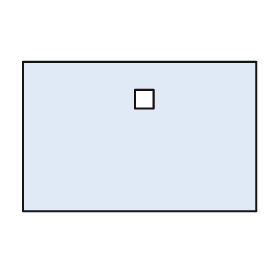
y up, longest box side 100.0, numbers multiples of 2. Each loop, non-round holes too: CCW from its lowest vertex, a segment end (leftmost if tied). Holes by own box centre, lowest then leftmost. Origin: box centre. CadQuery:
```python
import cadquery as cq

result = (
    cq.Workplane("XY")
    .moveTo(-50.0, -32.0)
    .lineTo(50.0, -32.0)
    .lineTo(50.0, 32.0)
    .lineTo(-50.0, 32.0)
    .close()
    .moveTo(-2.0, 12.0)
    .lineTo(6.0, 12.0)
    .lineTo(6.0, 20.0)
    .lineTo(-2.0, 20.0)
    .close()
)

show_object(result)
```